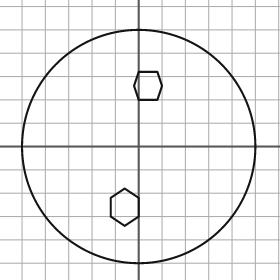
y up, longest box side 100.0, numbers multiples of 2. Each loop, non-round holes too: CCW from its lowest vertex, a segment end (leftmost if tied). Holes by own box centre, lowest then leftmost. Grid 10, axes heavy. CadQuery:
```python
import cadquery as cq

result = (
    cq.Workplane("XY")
    .moveTo(0.0, 0.0)
    .circle(50.0)
    .moveTo(-6.0, -34.0)
    .lineTo(0.0, -30.0)
    .lineTo(0.0, -22.0)
    .lineTo(-6.0, -18.0)
    .lineTo(-12.0, -22.0)
    .lineTo(-12.0, -30.0)
    .close()
    .moveTo(0.0, 20.0)
    .lineTo(8.0, 20.0)
    .lineTo(10.0, 26.0)
    .lineTo(8.0, 32.0)
    .lineTo(0.0, 32.0)
    .lineTo(-2.0, 26.0)
    .close()
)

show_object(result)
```